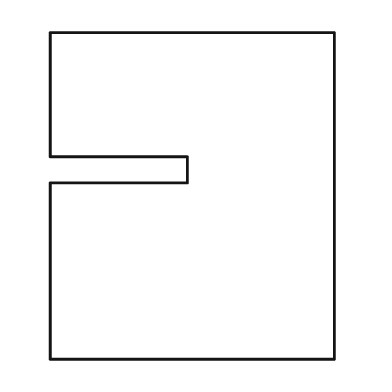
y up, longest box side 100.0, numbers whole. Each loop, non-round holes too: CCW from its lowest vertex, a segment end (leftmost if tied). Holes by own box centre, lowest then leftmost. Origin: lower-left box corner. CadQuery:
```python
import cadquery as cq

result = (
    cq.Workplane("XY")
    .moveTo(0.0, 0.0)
    .lineTo(87.0, 0.0)
    .lineTo(87.0, 100.0)
    .lineTo(0.0, 100.0)
    .lineTo(0.0, 62.0)
    .lineTo(42.0, 62.0)
    .lineTo(42.0, 54.0)
    .lineTo(0.0, 54.0)
    .close()
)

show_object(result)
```